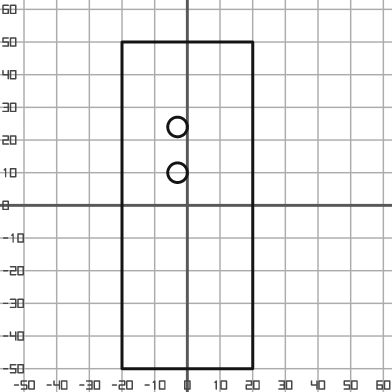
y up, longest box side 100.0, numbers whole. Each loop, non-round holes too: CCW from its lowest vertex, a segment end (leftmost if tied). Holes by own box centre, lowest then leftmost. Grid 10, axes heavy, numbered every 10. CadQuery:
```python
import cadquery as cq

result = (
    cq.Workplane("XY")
    .moveTo(-20.0, -50.0)
    .lineTo(20.0, -50.0)
    .lineTo(20.0, 50.0)
    .lineTo(-20.0, 50.0)
    .close()
    .moveTo(-3.0, 10.0)
    .circle(3.0)
    .moveTo(-3.0, 24.0)
    .circle(3.0)
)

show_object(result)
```